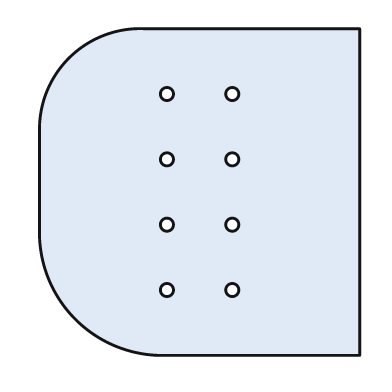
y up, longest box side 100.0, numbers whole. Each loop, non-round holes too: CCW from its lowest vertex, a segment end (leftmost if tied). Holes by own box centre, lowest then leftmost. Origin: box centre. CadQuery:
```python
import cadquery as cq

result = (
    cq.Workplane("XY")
    .moveTo(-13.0, -50.0)
    .lineTo(49.0, -50.0)
    .lineTo(49.0, 50.0)
    .lineTo(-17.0, 50.0)
    .threePointArc((-40.0, 41.0), (-49.0, 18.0))
    .lineTo(-49.0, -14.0)
    .threePointArc((-38.0, -39.0), (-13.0, -50.0))
    .close()
    .moveTo(-10.0, -30.0)
    .circle(2.0)
    .moveTo(10.0, -30.0)
    .circle(2.0)
    .moveTo(-10.0, -10.0)
    .circle(2.0)
    .moveTo(10.0, -10.0)
    .circle(2.0)
    .moveTo(-10.0, 10.0)
    .circle(2.0)
    .moveTo(10.0, 10.0)
    .circle(2.0)
    .moveTo(-10.0, 30.0)
    .circle(2.0)
    .moveTo(10.0, 30.0)
    .circle(2.0)
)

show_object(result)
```